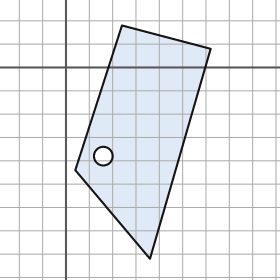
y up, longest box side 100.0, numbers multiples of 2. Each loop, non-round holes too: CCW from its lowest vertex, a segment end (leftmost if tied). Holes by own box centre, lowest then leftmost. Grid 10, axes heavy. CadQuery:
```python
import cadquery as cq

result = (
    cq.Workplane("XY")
    .moveTo(36.0, -82.0)
    .lineTo(62.0, 8.0)
    .lineTo(24.0, 18.0)
    .lineTo(4.0, -44.0)
    .close()
    .moveTo(16.0, -38.0)
    .circle(4.0)
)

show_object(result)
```